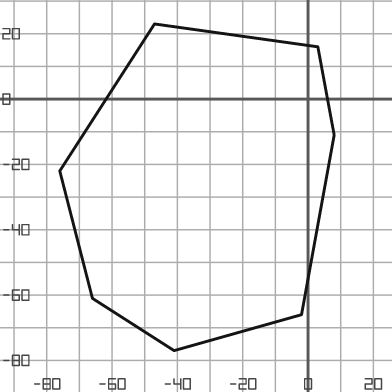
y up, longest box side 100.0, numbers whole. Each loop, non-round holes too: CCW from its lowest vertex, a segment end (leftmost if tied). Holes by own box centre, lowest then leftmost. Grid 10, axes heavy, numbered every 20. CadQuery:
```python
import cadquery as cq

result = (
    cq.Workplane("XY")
    .moveTo(-41.0, -77.0)
    .lineTo(-2.0, -66.0)
    .lineTo(8.0, -11.0)
    .lineTo(3.0, 16.0)
    .lineTo(-47.0, 23.0)
    .lineTo(-76.0, -22.0)
    .lineTo(-66.0, -61.0)
    .close()
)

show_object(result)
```